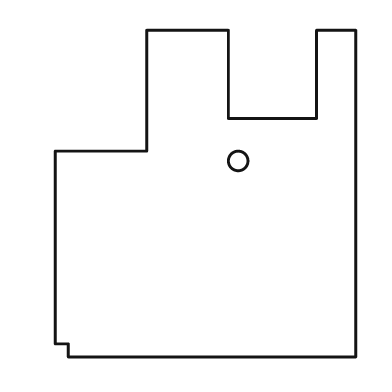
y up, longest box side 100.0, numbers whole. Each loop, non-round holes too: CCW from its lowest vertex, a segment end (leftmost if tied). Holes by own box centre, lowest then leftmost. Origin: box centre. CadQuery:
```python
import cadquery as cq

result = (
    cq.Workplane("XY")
    .moveTo(-42.0, -50.0)
    .lineTo(46.0, -50.0)
    .lineTo(46.0, 50.0)
    .lineTo(34.0, 50.0)
    .lineTo(34.0, 23.0)
    .lineTo(7.0, 23.0)
    .lineTo(7.0, 50.0)
    .lineTo(-18.0, 50.0)
    .lineTo(-18.0, 13.0)
    .lineTo(-46.0, 13.0)
    .lineTo(-46.0, -46.0)
    .lineTo(-42.0, -46.0)
    .close()
    .moveTo(10.0, 10.0)
    .circle(3.0)
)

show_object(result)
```